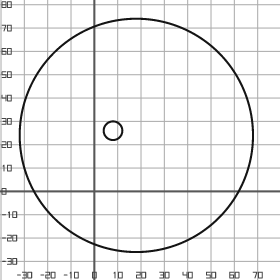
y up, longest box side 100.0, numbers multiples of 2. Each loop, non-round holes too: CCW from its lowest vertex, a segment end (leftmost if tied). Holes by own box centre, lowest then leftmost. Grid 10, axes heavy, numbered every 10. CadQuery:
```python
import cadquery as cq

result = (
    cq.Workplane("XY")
    .moveTo(18.0, 24.0)
    .circle(50.0)
    .moveTo(8.0, 26.0)
    .circle(4.0)
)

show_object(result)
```